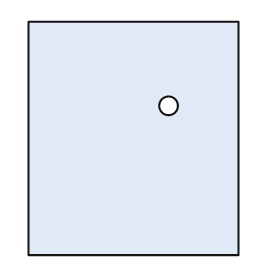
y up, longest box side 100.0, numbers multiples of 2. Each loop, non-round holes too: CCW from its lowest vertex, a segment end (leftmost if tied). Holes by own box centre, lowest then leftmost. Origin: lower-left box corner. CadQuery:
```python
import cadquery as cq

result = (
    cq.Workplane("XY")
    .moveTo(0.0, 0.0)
    .lineTo(90.0, 0.0)
    .lineTo(90.0, 100.0)
    .lineTo(0.0, 100.0)
    .close()
    .moveTo(60.0, 64.0)
    .circle(4.0)
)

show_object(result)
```